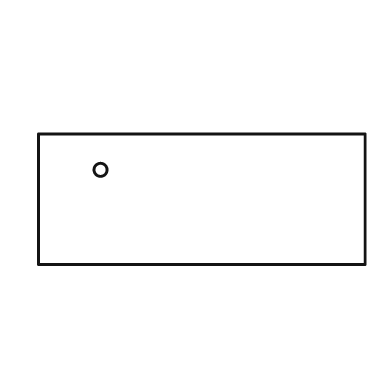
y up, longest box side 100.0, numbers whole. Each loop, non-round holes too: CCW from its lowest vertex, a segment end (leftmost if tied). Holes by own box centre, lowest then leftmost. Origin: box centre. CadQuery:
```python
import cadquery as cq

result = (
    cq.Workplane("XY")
    .moveTo(-50.0, -20.0)
    .lineTo(50.0, -20.0)
    .lineTo(50.0, 20.0)
    .lineTo(-50.0, 20.0)
    .close()
    .moveTo(-31.0, 9.0)
    .circle(2.0)
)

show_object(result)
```